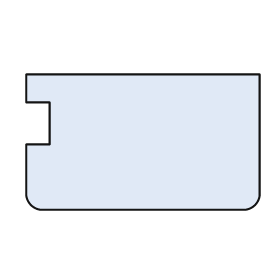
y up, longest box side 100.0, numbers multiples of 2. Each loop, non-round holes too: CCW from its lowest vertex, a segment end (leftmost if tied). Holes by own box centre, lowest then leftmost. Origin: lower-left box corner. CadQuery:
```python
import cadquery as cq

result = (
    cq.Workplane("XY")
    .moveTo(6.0, 0.0)
    .lineTo(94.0, 0.0)
    .threePointArc((98.0, 2.0), (100.0, 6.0))
    .lineTo(100.0, 58.0)
    .lineTo(0.0, 58.0)
    .lineTo(0.0, 46.0)
    .lineTo(10.0, 46.0)
    .lineTo(10.0, 28.0)
    .lineTo(0.0, 28.0)
    .lineTo(0.0, 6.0)
    .threePointArc((2.0, 2.0), (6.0, 0.0))
    .close()
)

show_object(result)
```